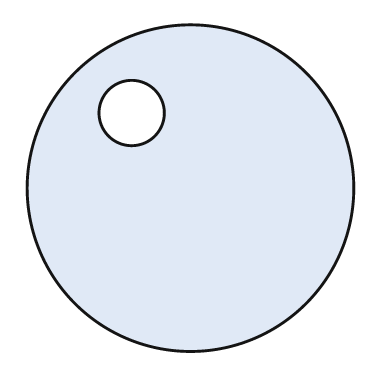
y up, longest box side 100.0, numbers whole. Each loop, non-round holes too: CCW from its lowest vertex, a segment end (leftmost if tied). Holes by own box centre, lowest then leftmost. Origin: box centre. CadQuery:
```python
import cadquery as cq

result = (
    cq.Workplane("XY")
    .moveTo(0.0, 0.0)
    .circle(50.0)
    .moveTo(-18.0, 23.0)
    .circle(10.0)
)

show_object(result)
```